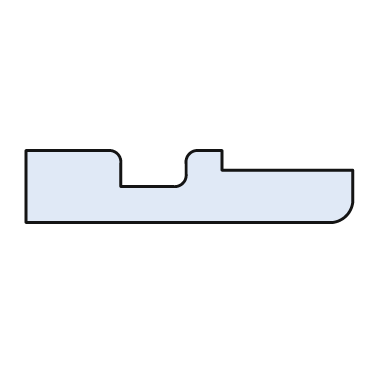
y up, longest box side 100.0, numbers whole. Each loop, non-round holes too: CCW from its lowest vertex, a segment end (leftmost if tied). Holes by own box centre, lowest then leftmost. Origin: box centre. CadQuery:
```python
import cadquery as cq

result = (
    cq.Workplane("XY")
    .moveTo(-50.0, -11.0)
    .lineTo(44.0, -11.0)
    .threePointArc((48.0, -9.0), (50.0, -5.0))
    .lineTo(50.0, 5.0)
    .lineTo(10.0, 5.0)
    .lineTo(10.0, 11.0)
    .lineTo(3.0, 11.0)
    .threePointArc((0.0, 10.0), (-1.0, 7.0))
    .lineTo(-1.0, 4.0)
    .threePointArc((-2.0, 1.0), (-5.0, 0.0))
    .lineTo(-21.0, 0.0)
    .lineTo(-21.0, 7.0)
    .threePointArc((-22.0, 10.0), (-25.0, 11.0))
    .lineTo(-50.0, 11.0)
    .close()
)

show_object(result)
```